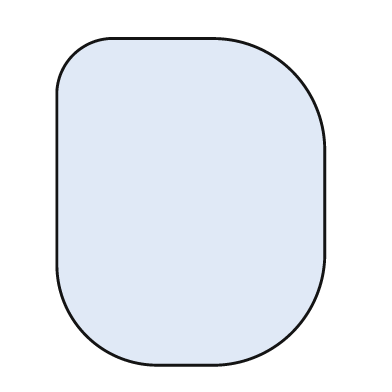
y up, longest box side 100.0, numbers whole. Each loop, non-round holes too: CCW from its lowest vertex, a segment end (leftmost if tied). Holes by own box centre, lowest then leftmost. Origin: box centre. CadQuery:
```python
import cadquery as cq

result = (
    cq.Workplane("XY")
    .moveTo(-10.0, -50.0)
    .lineTo(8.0, -50.0)
    .threePointArc((31.0, -40.0), (41.0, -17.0))
    .lineTo(41.0, 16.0)
    .threePointArc((31.0, 40.0), (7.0, 50.0))
    .lineTo(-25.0, 50.0)
    .threePointArc((-36.0, 45.0), (-41.0, 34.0))
    .lineTo(-41.0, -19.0)
    .threePointArc((-32.0, -41.0), (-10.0, -50.0))
    .close()
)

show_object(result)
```